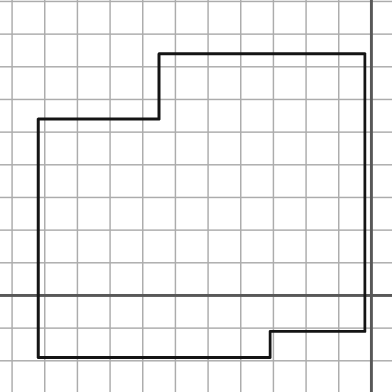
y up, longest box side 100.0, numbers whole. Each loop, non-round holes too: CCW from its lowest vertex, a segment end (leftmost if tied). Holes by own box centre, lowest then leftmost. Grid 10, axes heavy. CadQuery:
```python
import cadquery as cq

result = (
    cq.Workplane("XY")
    .moveTo(-102.0, -19.0)
    .lineTo(-31.0, -19.0)
    .lineTo(-31.0, -11.0)
    .lineTo(-2.0, -11.0)
    .lineTo(-2.0, 74.0)
    .lineTo(-65.0, 74.0)
    .lineTo(-65.0, 54.0)
    .lineTo(-102.0, 54.0)
    .close()
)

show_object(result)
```